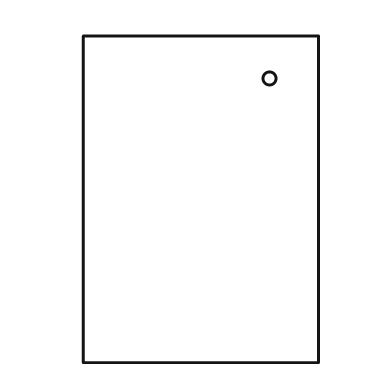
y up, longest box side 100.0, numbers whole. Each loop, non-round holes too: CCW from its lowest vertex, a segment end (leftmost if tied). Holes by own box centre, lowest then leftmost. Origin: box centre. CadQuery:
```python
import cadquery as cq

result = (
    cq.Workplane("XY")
    .moveTo(-36.0, -50.0)
    .lineTo(36.0, -50.0)
    .lineTo(36.0, 50.0)
    .lineTo(-36.0, 50.0)
    .close()
    .moveTo(21.0, 37.0)
    .circle(2.0)
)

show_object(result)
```